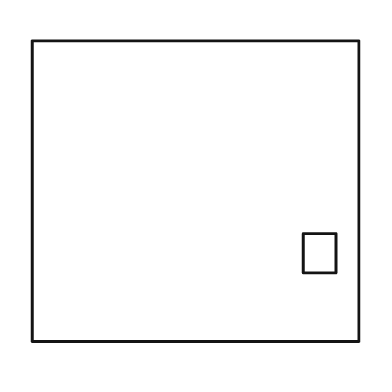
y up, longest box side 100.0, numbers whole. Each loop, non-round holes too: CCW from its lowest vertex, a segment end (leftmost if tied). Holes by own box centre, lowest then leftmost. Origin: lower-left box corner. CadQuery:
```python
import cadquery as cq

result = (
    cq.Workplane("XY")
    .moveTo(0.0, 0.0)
    .lineTo(100.0, 0.0)
    .lineTo(100.0, 92.0)
    .lineTo(0.0, 92.0)
    .close()
    .moveTo(83.0, 21.0)
    .lineTo(93.0, 21.0)
    .lineTo(93.0, 33.0)
    .lineTo(83.0, 33.0)
    .close()
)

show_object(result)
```